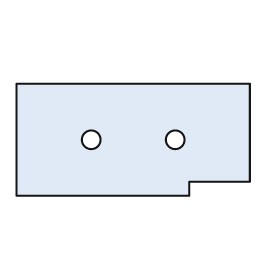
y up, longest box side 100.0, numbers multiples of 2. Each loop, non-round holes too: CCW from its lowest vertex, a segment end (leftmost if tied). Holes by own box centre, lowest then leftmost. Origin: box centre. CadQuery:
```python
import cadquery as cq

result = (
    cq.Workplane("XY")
    .moveTo(-50.0, -24.0)
    .lineTo(24.0, -24.0)
    .lineTo(24.0, -18.0)
    .lineTo(50.0, -18.0)
    .lineTo(50.0, 24.0)
    .lineTo(-50.0, 24.0)
    .close()
    .moveTo(-18.0, 0.0)
    .circle(4.0)
    .moveTo(18.0, 0.0)
    .circle(4.0)
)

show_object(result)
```